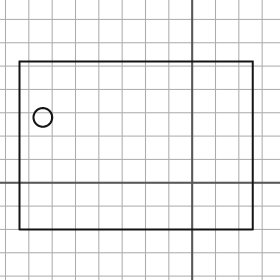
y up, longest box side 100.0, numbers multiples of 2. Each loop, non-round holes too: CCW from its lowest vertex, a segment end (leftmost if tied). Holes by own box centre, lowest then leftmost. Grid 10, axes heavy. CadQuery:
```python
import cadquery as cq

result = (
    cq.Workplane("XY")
    .moveTo(-74.0, -20.0)
    .lineTo(26.0, -20.0)
    .lineTo(26.0, 52.0)
    .lineTo(-74.0, 52.0)
    .close()
    .moveTo(-64.0, 28.0)
    .circle(4.0)
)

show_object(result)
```